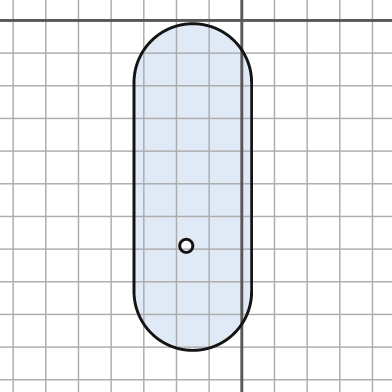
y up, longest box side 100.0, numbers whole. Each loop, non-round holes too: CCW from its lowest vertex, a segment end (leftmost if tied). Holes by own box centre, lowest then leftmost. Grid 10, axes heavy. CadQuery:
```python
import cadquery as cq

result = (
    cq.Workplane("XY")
    .moveTo(-33.0, -83.0)
    .threePointArc((-15.0, -101.0), (3.0, -83.0))
    .lineTo(3.0, -19.0)
    .threePointArc((-15.0, -1.0), (-33.0, -19.0))
    .close()
    .moveTo(-17.0, -69.0)
    .circle(2.0)
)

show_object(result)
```